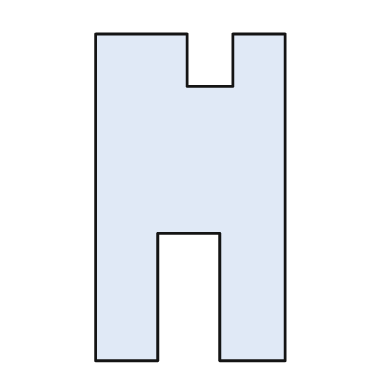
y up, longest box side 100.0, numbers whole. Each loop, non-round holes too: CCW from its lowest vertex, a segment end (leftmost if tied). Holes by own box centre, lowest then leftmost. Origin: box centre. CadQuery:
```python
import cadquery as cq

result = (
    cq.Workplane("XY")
    .moveTo(-29.0, -50.0)
    .lineTo(-10.0, -50.0)
    .lineTo(-10.0, -11.0)
    .lineTo(9.0, -11.0)
    .lineTo(9.0, -50.0)
    .lineTo(29.0, -50.0)
    .lineTo(29.0, 50.0)
    .lineTo(13.0, 50.0)
    .lineTo(13.0, 34.0)
    .lineTo(-1.0, 34.0)
    .lineTo(-1.0, 50.0)
    .lineTo(-29.0, 50.0)
    .close()
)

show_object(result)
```